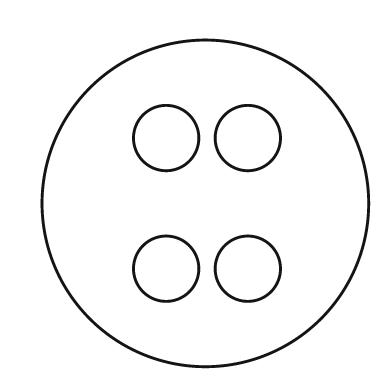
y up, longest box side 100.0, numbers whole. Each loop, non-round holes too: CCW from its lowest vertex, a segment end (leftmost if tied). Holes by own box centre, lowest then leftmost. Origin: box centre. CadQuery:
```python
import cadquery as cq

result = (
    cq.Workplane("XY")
    .moveTo(0.0, 0.0)
    .circle(50.0)
    .moveTo(-12.0, -20.0)
    .circle(10.0)
    .moveTo(13.0, -20.0)
    .circle(10.0)
    .moveTo(-12.0, 20.0)
    .circle(10.0)
    .moveTo(13.0, 20.0)
    .circle(10.0)
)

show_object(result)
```